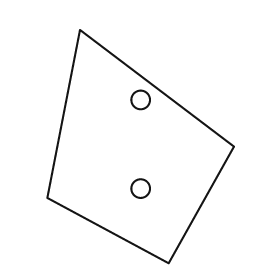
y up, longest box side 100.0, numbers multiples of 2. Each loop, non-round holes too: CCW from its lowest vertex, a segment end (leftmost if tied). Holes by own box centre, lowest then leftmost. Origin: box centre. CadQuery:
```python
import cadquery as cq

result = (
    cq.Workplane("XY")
    .moveTo(12.0, -50.0)
    .lineTo(40.0, 0.0)
    .lineTo(-26.0, 50.0)
    .lineTo(-40.0, -22.0)
    .close()
    .moveTo(0.0, -18.0)
    .circle(4.0)
    .moveTo(0.0, 20.0)
    .circle(4.0)
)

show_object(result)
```